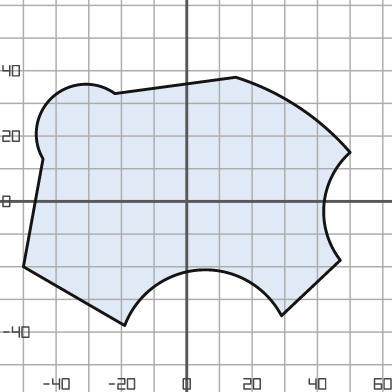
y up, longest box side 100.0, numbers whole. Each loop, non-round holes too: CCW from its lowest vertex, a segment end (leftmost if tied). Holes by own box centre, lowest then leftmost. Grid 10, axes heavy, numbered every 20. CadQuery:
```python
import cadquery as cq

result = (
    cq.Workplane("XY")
    .moveTo(-19.0, -38.0)
    .threePointArc((4.0, -21.0), (29.0, -35.0))
    .lineTo(47.0, -18.0)
    .threePointArc((42.0, -1.0), (50.0, 15.0))
    .threePointArc((34.0, 29.0), (15.0, 38.0))
    .lineTo(-22.0, 33.0)
    .threePointArc((-41.0, 32.0), (-44.0, 13.0))
    .lineTo(-50.0, -20.0)
    .close()
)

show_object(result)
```